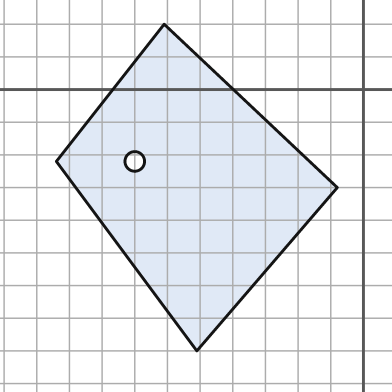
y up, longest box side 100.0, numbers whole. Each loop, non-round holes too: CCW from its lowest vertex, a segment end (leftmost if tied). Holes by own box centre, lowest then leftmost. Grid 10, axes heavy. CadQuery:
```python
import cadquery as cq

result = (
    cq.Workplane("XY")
    .moveTo(-51.0, -80.0)
    .lineTo(-8.0, -30.0)
    .lineTo(-61.0, 20.0)
    .lineTo(-94.0, -22.0)
    .close()
    .moveTo(-70.0, -22.0)
    .circle(3.0)
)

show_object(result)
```